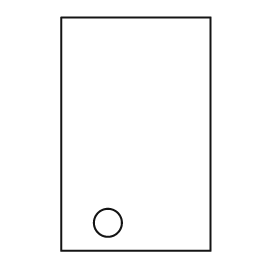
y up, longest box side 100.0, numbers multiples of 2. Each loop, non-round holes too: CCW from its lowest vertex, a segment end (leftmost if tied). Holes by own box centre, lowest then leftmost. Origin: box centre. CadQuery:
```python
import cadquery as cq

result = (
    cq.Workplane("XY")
    .moveTo(-32.0, -50.0)
    .lineTo(32.0, -50.0)
    .lineTo(32.0, 50.0)
    .lineTo(-32.0, 50.0)
    .close()
    .moveTo(-12.0, -38.0)
    .circle(6.0)
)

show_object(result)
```